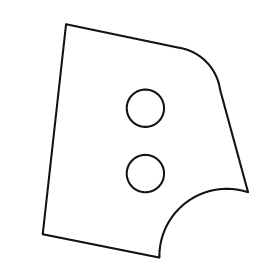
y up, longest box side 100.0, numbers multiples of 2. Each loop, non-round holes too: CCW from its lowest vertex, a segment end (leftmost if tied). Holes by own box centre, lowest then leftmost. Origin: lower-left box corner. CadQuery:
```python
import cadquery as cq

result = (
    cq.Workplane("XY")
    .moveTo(50.0, 0.0)
    .threePointArc((62.0, 24.0), (88.0, 28.0))
    .lineTo(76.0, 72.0)
    .threePointArc((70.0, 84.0), (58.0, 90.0))
    .lineTo(10.0, 100.0)
    .lineTo(0.0, 10.0)
    .close()
    .moveTo(44.0, 36.0)
    .circle(8.0)
    .moveTo(44.0, 64.0)
    .circle(8.0)
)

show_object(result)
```